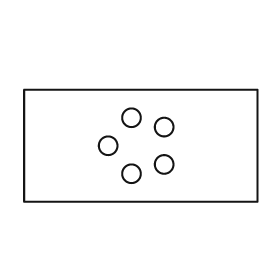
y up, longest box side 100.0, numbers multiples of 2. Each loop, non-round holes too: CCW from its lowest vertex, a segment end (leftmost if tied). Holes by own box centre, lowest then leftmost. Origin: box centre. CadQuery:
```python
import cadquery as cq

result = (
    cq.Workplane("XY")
    .moveTo(-50.0, -24.0)
    .lineTo(50.0, -24.0)
    .lineTo(50.0, 24.0)
    .lineTo(-50.0, 24.0)
    .close()
    .moveTo(-4.0, -12.0)
    .circle(4.0)
    .moveTo(10.0, -8.0)
    .circle(4.0)
    .moveTo(-14.0, 0.0)
    .circle(4.0)
    .moveTo(10.0, 8.0)
    .circle(4.0)
    .moveTo(-4.0, 12.0)
    .circle(4.0)
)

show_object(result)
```